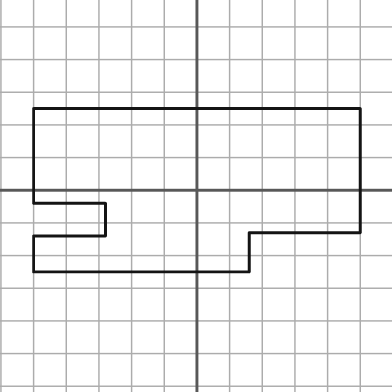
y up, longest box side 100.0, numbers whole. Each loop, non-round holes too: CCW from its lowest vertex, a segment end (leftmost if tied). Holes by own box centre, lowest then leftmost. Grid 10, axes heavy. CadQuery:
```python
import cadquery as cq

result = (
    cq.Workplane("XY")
    .moveTo(-50.0, -25.0)
    .lineTo(16.0, -25.0)
    .lineTo(16.0, -13.0)
    .lineTo(50.0, -13.0)
    .lineTo(50.0, 25.0)
    .lineTo(-50.0, 25.0)
    .lineTo(-50.0, -4.0)
    .lineTo(-28.0, -4.0)
    .lineTo(-28.0, -14.0)
    .lineTo(-50.0, -14.0)
    .close()
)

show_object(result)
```